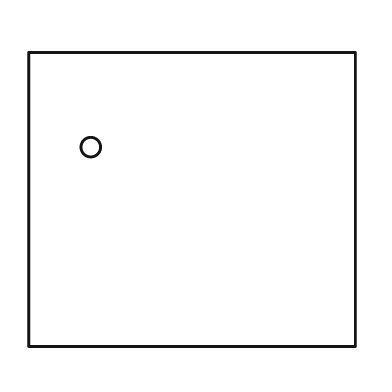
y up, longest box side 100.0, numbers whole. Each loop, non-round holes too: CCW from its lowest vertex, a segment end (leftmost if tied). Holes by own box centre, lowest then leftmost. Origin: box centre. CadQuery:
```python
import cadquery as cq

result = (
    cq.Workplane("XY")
    .moveTo(-50.0, -45.0)
    .lineTo(50.0, -45.0)
    .lineTo(50.0, 45.0)
    .lineTo(-50.0, 45.0)
    .close()
    .moveTo(-31.0, 16.0)
    .circle(3.0)
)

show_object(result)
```